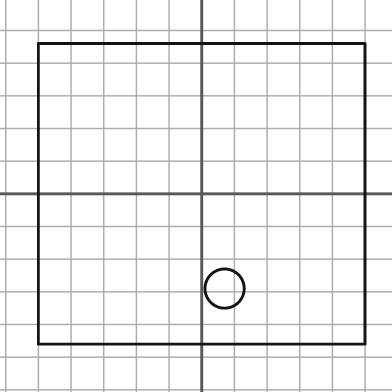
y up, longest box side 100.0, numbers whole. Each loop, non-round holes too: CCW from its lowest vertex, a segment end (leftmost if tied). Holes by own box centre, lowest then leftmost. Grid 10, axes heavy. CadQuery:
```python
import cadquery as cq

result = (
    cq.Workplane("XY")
    .moveTo(-50.0, -46.0)
    .lineTo(50.0, -46.0)
    .lineTo(50.0, 46.0)
    .lineTo(-50.0, 46.0)
    .close()
    .moveTo(7.0, -29.0)
    .circle(6.0)
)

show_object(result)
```